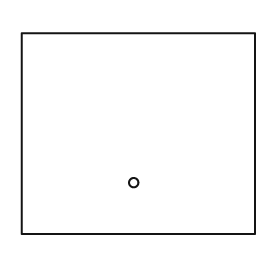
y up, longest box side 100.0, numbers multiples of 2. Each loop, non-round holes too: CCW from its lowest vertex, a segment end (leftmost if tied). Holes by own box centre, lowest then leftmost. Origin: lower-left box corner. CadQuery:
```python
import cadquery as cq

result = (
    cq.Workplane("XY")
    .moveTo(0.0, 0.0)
    .lineTo(100.0, 0.0)
    .lineTo(100.0, 86.0)
    .lineTo(0.0, 86.0)
    .close()
    .moveTo(48.0, 22.0)
    .circle(2.0)
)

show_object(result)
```